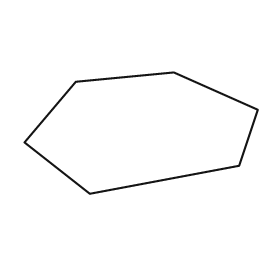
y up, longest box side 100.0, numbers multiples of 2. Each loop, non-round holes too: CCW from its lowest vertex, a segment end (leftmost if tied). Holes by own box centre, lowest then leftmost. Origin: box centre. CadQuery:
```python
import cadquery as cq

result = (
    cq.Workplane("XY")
    .moveTo(-22.0, -26.0)
    .lineTo(42.0, -14.0)
    .lineTo(50.0, 10.0)
    .lineTo(14.0, 26.0)
    .lineTo(-28.0, 22.0)
    .lineTo(-50.0, -4.0)
    .close()
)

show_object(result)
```